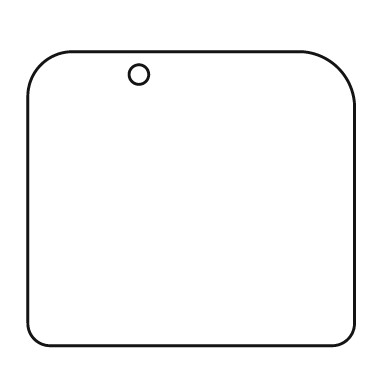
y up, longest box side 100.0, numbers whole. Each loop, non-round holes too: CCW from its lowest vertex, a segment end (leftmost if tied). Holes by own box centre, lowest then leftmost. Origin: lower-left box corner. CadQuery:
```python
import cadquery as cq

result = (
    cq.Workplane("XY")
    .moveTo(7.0, 0.0)
    .lineTo(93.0, 0.0)
    .threePointArc((98.0, 2.0), (100.0, 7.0))
    .lineTo(100.0, 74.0)
    .threePointArc((95.0, 85.0), (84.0, 90.0))
    .lineTo(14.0, 90.0)
    .threePointArc((4.0, 86.0), (0.0, 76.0))
    .lineTo(0.0, 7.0)
    .threePointArc((2.0, 2.0), (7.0, 0.0))
    .close()
    .moveTo(34.0, 83.0)
    .circle(3.0)
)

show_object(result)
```